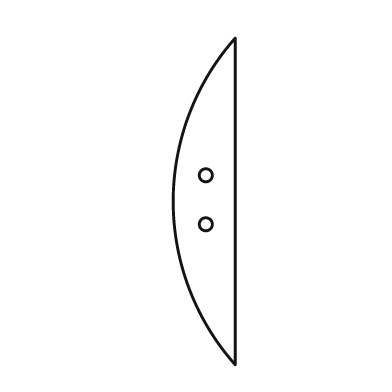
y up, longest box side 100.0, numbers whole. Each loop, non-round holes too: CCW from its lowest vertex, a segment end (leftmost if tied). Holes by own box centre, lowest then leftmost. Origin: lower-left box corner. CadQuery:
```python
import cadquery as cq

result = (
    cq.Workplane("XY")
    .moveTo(19.0, 0.0)
    .lineTo(19.0, 100.0)
    .threePointArc((0.0, 50.0), (19.0, 0.0))
    .close()
    .moveTo(10.0, 43.0)
    .circle(2.0)
    .moveTo(10.0, 58.0)
    .circle(2.0)
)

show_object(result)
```